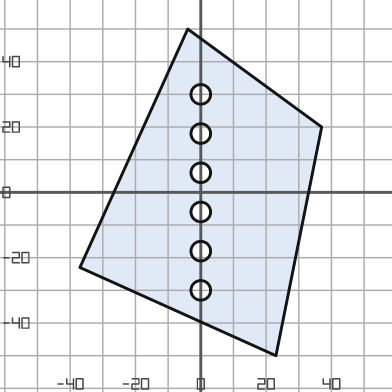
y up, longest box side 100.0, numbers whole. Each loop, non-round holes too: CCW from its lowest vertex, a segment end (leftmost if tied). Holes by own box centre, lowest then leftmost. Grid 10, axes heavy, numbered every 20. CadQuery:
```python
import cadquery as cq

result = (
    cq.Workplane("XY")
    .moveTo(23.0, -50.0)
    .lineTo(37.0, 20.0)
    .lineTo(-4.0, 50.0)
    .lineTo(-37.0, -23.0)
    .close()
    .moveTo(0.0, -30.0)
    .circle(3.0)
    .moveTo(0.0, -18.0)
    .circle(3.0)
    .moveTo(0.0, -6.0)
    .circle(3.0)
    .moveTo(0.0, 6.0)
    .circle(3.0)
    .moveTo(0.0, 18.0)
    .circle(3.0)
    .moveTo(0.0, 30.0)
    .circle(3.0)
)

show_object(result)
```